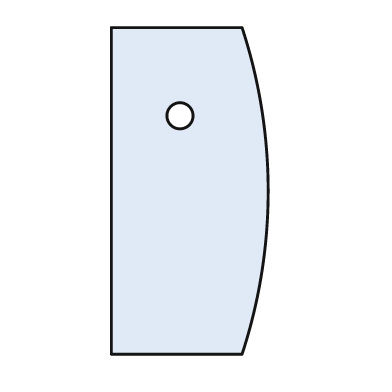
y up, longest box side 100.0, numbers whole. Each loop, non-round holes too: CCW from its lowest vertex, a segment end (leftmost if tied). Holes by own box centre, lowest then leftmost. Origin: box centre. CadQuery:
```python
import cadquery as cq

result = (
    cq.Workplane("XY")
    .moveTo(-24.0, -50.0)
    .lineTo(16.0, -50.0)
    .threePointArc((24.0, 0.0), (16.0, 50.0))
    .lineTo(-24.0, 50.0)
    .close()
    .moveTo(-3.0, 23.0)
    .circle(4.0)
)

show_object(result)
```